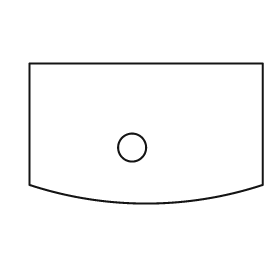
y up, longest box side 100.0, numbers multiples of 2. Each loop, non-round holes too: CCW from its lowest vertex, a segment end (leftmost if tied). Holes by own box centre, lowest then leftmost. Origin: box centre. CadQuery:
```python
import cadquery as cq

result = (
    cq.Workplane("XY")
    .moveTo(-50.0, -22.0)
    .threePointArc((0.0, -30.0), (50.0, -22.0))
    .lineTo(50.0, 30.0)
    .lineTo(-50.0, 30.0)
    .close()
    .moveTo(-6.0, -6.0)
    .circle(6.0)
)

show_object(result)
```